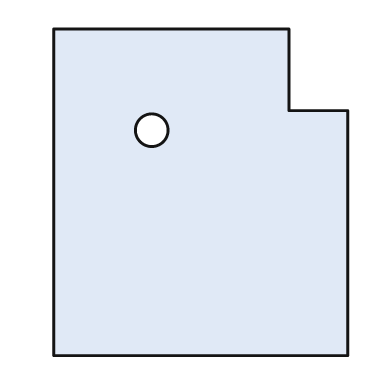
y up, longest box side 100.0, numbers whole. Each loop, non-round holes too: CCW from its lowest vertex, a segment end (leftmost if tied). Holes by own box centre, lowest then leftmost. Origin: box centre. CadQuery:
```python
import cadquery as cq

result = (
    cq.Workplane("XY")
    .moveTo(-45.0, -50.0)
    .lineTo(45.0, -50.0)
    .lineTo(45.0, 25.0)
    .lineTo(27.0, 25.0)
    .lineTo(27.0, 50.0)
    .lineTo(-45.0, 50.0)
    .close()
    .moveTo(-15.0, 19.0)
    .circle(5.0)
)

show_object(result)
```